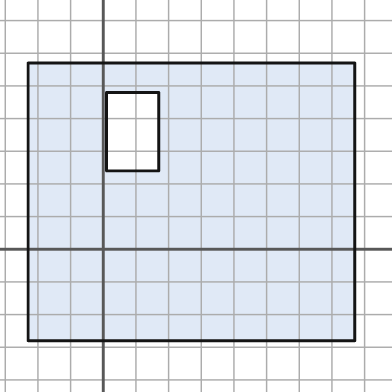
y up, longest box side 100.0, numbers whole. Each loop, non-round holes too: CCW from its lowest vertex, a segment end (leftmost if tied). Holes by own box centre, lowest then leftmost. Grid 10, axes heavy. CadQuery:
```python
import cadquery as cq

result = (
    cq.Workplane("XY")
    .moveTo(-23.0, -28.0)
    .lineTo(77.0, -28.0)
    .lineTo(77.0, 57.0)
    .lineTo(-23.0, 57.0)
    .close()
    .moveTo(1.0, 24.0)
    .lineTo(17.0, 24.0)
    .lineTo(17.0, 48.0)
    .lineTo(1.0, 48.0)
    .close()
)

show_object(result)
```